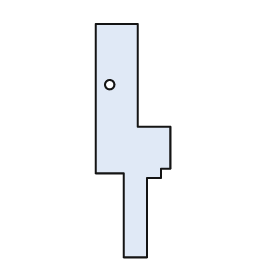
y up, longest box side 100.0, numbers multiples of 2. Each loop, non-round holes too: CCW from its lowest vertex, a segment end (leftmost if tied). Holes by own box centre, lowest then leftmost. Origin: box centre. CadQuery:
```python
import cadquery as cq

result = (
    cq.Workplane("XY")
    .moveTo(-4.0, -50.0)
    .lineTo(6.0, -50.0)
    .lineTo(6.0, -16.0)
    .lineTo(12.0, -16.0)
    .lineTo(12.0, -12.0)
    .lineTo(16.0, -12.0)
    .lineTo(16.0, 6.0)
    .lineTo(2.0, 6.0)
    .lineTo(2.0, 50.0)
    .lineTo(-16.0, 50.0)
    .lineTo(-16.0, -14.0)
    .lineTo(-4.0, -14.0)
    .close()
    .moveTo(-10.0, 24.0)
    .circle(2.0)
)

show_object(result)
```